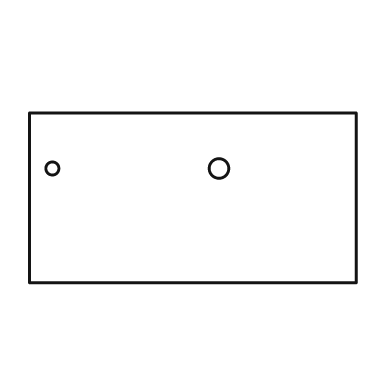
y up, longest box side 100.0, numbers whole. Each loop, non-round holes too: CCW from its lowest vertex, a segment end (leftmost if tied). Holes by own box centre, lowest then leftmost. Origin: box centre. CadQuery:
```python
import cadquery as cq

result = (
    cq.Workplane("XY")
    .moveTo(-50.0, -26.0)
    .lineTo(50.0, -26.0)
    .lineTo(50.0, 26.0)
    .lineTo(-50.0, 26.0)
    .close()
    .moveTo(-43.0, 9.0)
    .circle(2.0)
    .moveTo(8.0, 9.0)
    .circle(3.0)
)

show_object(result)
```